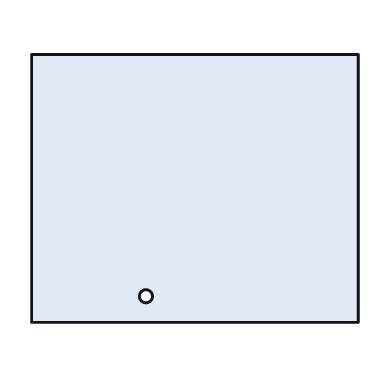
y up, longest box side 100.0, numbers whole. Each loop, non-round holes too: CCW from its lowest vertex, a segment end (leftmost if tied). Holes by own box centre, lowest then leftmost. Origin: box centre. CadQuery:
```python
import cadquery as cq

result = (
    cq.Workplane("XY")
    .moveTo(-50.0, -41.0)
    .lineTo(50.0, -41.0)
    .lineTo(50.0, 41.0)
    .lineTo(-50.0, 41.0)
    .close()
    .moveTo(-15.0, -33.0)
    .circle(2.0)
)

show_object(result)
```